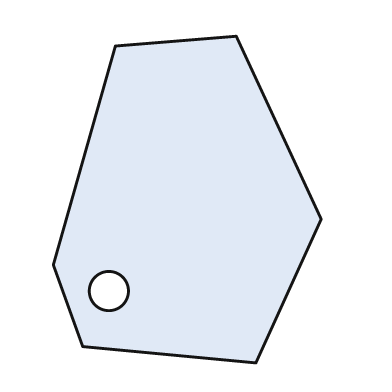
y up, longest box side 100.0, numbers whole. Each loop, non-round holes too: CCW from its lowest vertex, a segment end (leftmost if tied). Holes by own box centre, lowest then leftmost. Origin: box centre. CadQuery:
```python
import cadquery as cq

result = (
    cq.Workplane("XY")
    .moveTo(21.0, -50.0)
    .lineTo(41.0, -6.0)
    .lineTo(15.0, 50.0)
    .lineTo(-22.0, 47.0)
    .lineTo(-41.0, -20.0)
    .lineTo(-32.0, -45.0)
    .close()
    .moveTo(-24.0, -28.0)
    .circle(6.0)
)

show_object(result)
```